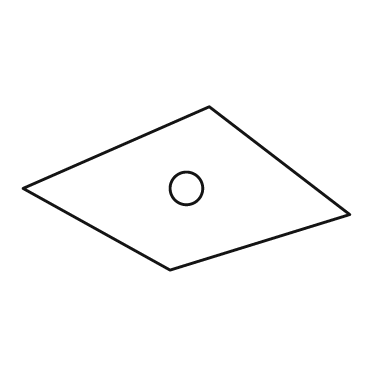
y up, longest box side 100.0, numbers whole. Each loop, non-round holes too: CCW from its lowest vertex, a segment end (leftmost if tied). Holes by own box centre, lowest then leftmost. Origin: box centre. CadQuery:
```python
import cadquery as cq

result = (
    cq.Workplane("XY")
    .moveTo(-5.0, -25.0)
    .lineTo(50.0, -8.0)
    .lineTo(7.0, 25.0)
    .lineTo(-50.0, 0.0)
    .close()
    .moveTo(0.0, 0.0)
    .circle(5.0)
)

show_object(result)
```